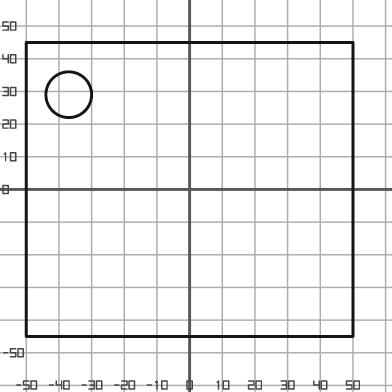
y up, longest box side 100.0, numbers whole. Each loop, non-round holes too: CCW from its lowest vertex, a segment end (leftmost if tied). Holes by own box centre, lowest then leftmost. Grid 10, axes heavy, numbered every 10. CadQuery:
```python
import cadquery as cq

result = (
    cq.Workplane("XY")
    .moveTo(-50.0, -45.0)
    .lineTo(50.0, -45.0)
    .lineTo(50.0, 45.0)
    .lineTo(-50.0, 45.0)
    .close()
    .moveTo(-37.0, 29.0)
    .circle(7.0)
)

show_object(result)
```